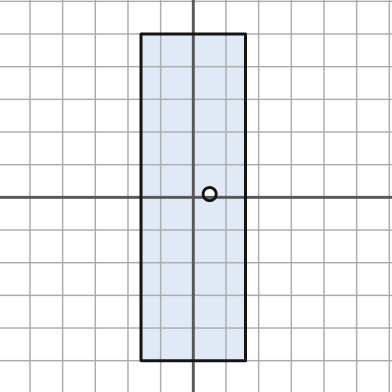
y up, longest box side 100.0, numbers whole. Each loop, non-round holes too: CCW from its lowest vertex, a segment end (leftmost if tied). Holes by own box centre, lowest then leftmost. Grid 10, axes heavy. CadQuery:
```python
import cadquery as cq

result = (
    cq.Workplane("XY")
    .moveTo(-16.0, -50.0)
    .lineTo(16.0, -50.0)
    .lineTo(16.0, 50.0)
    .lineTo(-16.0, 50.0)
    .close()
    .moveTo(5.0, 1.0)
    .circle(2.0)
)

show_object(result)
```